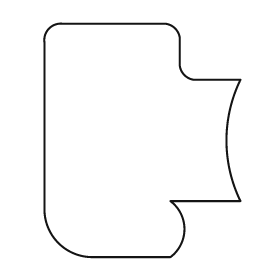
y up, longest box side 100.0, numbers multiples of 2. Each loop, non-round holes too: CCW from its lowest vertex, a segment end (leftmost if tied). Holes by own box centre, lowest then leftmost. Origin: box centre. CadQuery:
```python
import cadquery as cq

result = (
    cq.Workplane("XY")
    .moveTo(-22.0, -50.0)
    .lineTo(12.0, -50.0)
    .threePointArc((18.0, -38.0), (12.0, -26.0))
    .lineTo(42.0, -26.0)
    .threePointArc((36.0, 0.0), (42.0, 26.0))
    .lineTo(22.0, 26.0)
    .threePointArc((18.0, 28.0), (16.0, 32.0))
    .lineTo(16.0, 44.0)
    .threePointArc((14.0, 48.0), (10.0, 50.0))
    .lineTo(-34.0, 50.0)
    .threePointArc((-40.0, 48.0), (-42.0, 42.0))
    .lineTo(-42.0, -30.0)
    .threePointArc((-36.0, -44.0), (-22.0, -50.0))
    .close()
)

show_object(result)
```